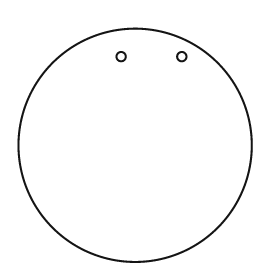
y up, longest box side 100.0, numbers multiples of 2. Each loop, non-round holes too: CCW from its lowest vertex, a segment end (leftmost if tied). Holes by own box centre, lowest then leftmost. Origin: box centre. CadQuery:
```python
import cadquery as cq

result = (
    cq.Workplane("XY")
    .moveTo(0.0, 0.0)
    .circle(50.0)
    .moveTo(-6.0, 38.0)
    .circle(2.0)
    .moveTo(20.0, 38.0)
    .circle(2.0)
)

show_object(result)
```